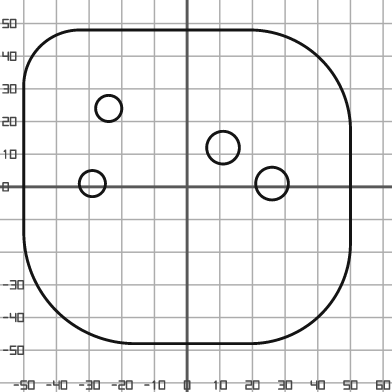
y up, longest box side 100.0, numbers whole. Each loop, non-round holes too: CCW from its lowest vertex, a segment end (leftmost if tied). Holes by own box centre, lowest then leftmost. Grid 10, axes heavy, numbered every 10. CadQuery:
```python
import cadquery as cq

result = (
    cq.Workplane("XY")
    .moveTo(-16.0, -48.0)
    .lineTo(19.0, -48.0)
    .threePointArc((41.0, -39.0), (50.0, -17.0))
    .lineTo(50.0, 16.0)
    .threePointArc((41.0, 39.0), (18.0, 48.0))
    .lineTo(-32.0, 48.0)
    .threePointArc((-45.0, 43.0), (-50.0, 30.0))
    .lineTo(-50.0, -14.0)
    .threePointArc((-40.0, -38.0), (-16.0, -48.0))
    .close()
    .moveTo(-29.0, 1.0)
    .circle(4.0)
    .moveTo(26.0, 1.0)
    .circle(5.0)
    .moveTo(11.0, 12.0)
    .circle(5.0)
    .moveTo(-24.0, 24.0)
    .circle(4.0)
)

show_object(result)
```